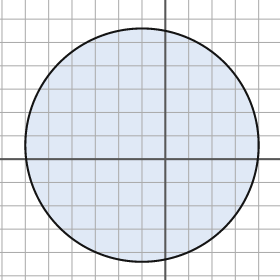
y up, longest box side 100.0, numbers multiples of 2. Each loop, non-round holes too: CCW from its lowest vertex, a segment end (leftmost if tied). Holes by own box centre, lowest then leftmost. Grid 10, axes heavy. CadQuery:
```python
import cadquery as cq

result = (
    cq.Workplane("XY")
    .moveTo(-10.0, 6.0)
    .circle(50.0)
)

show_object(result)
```